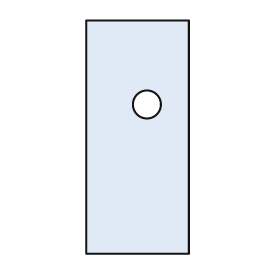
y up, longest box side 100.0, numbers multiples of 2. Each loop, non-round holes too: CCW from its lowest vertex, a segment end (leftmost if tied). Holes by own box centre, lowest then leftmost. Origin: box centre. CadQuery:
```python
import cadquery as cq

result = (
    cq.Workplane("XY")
    .moveTo(-22.0, -50.0)
    .lineTo(22.0, -50.0)
    .lineTo(22.0, 50.0)
    .lineTo(-22.0, 50.0)
    .close()
    .moveTo(4.0, 14.0)
    .circle(6.0)
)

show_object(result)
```